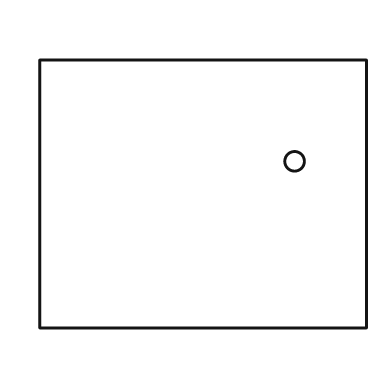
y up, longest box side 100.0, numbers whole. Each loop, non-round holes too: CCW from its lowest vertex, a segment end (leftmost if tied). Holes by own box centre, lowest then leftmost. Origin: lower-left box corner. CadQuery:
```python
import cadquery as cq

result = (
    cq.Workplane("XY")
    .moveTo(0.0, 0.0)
    .lineTo(100.0, 0.0)
    .lineTo(100.0, 82.0)
    .lineTo(0.0, 82.0)
    .close()
    .moveTo(78.0, 51.0)
    .circle(3.0)
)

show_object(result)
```